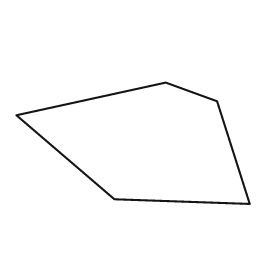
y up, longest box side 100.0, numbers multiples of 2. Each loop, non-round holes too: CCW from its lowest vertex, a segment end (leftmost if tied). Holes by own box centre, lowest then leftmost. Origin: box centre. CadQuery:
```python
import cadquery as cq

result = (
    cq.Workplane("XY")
    .moveTo(50.0, -26.0)
    .lineTo(36.0, 18.0)
    .lineTo(14.0, 26.0)
    .lineTo(-50.0, 12.0)
    .lineTo(-8.0, -24.0)
    .close()
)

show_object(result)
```